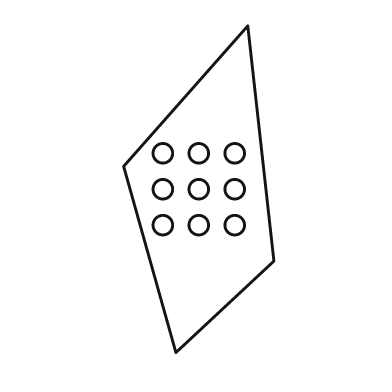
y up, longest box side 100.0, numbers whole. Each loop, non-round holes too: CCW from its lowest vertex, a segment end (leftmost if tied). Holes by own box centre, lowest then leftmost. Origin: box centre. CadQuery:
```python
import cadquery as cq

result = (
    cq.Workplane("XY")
    .moveTo(-7.0, -50.0)
    .lineTo(23.0, -22.0)
    .lineTo(15.0, 50.0)
    .lineTo(-23.0, 7.0)
    .close()
    .moveTo(-11.0, -11.0)
    .circle(3.0)
    .moveTo(0.0, -11.0)
    .circle(3.0)
    .moveTo(11.0, -11.0)
    .circle(3.0)
    .moveTo(-11.0, 0.0)
    .circle(3.0)
    .moveTo(0.0, 0.0)
    .circle(3.0)
    .moveTo(11.0, 0.0)
    .circle(3.0)
    .moveTo(-11.0, 11.0)
    .circle(3.0)
    .moveTo(0.0, 11.0)
    .circle(3.0)
    .moveTo(11.0, 11.0)
    .circle(3.0)
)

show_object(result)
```